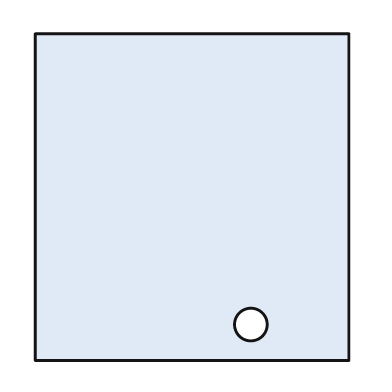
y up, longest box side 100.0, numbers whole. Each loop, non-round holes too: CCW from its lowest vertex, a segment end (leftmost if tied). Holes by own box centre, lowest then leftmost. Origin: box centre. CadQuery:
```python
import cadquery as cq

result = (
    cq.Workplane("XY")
    .moveTo(-48.0, -50.0)
    .lineTo(48.0, -50.0)
    .lineTo(48.0, 50.0)
    .lineTo(-48.0, 50.0)
    .close()
    .moveTo(18.0, -39.0)
    .circle(5.0)
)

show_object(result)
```